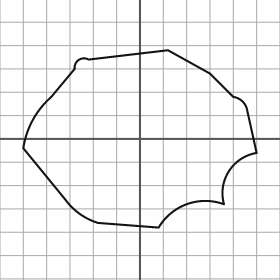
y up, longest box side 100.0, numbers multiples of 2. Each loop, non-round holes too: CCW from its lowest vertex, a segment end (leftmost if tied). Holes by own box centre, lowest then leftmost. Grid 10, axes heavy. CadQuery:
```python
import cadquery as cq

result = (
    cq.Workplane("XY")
    .moveTo(8.0, -38.0)
    .threePointArc((20.0, -28.0), (36.0, -28.0))
    .threePointArc((38.0, -14.0), (50.0, -6.0))
    .lineTo(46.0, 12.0)
    .threePointArc((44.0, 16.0), (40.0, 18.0))
    .lineTo(30.0, 28.0)
    .lineTo(12.0, 38.0)
    .lineTo(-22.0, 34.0)
    .threePointArc((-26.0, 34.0), (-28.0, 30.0))
    .lineTo(-38.0, 18.0)
    .threePointArc((-46.0, 8.0), (-50.0, -4.0))
    .lineTo(-32.0, -26.0)
    .threePointArc((-26.0, -32.0), (-18.0, -36.0))
    .close()
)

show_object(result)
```